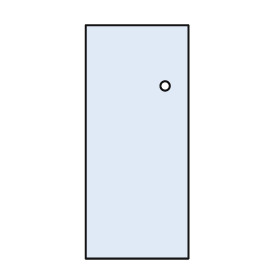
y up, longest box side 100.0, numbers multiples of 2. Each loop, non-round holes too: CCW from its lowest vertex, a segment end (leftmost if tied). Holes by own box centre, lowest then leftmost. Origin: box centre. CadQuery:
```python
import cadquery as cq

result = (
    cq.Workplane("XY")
    .moveTo(-22.0, -50.0)
    .lineTo(22.0, -50.0)
    .lineTo(22.0, 50.0)
    .lineTo(-22.0, 50.0)
    .close()
    .moveTo(12.0, 24.0)
    .circle(2.0)
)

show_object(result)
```